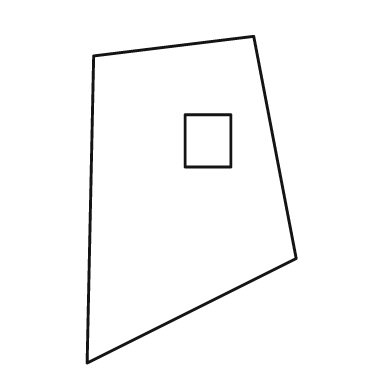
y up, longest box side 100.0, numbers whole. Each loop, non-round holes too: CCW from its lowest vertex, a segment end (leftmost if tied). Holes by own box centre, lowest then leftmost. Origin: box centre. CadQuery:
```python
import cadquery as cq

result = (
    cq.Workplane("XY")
    .moveTo(-32.0, -50.0)
    .lineTo(32.0, -18.0)
    .lineTo(19.0, 50.0)
    .lineTo(-30.0, 44.0)
    .close()
    .moveTo(-2.0, 10.0)
    .lineTo(12.0, 10.0)
    .lineTo(12.0, 26.0)
    .lineTo(-2.0, 26.0)
    .close()
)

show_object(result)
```